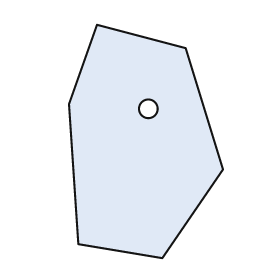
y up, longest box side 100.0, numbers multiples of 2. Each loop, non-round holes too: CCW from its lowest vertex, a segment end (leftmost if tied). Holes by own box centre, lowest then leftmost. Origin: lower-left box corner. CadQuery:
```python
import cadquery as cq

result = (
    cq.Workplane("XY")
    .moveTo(40.0, 0.0)
    .lineTo(66.0, 38.0)
    .lineTo(50.0, 90.0)
    .lineTo(12.0, 100.0)
    .lineTo(0.0, 66.0)
    .lineTo(4.0, 6.0)
    .close()
    .moveTo(34.0, 64.0)
    .circle(4.0)
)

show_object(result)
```